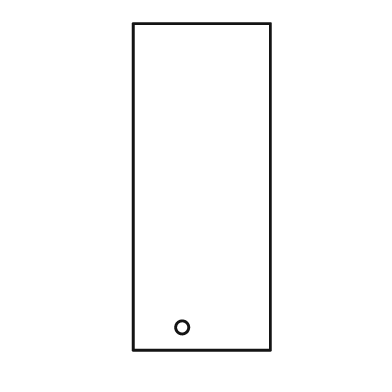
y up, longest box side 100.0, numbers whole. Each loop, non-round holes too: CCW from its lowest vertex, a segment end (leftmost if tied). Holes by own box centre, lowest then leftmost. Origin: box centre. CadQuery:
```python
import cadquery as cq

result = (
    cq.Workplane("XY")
    .moveTo(-21.0, -50.0)
    .lineTo(21.0, -50.0)
    .lineTo(21.0, 50.0)
    .lineTo(-21.0, 50.0)
    .close()
    .moveTo(-6.0, -43.0)
    .circle(2.0)
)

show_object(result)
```